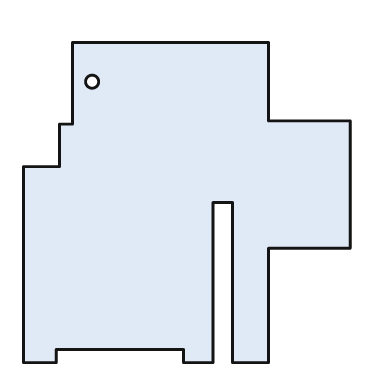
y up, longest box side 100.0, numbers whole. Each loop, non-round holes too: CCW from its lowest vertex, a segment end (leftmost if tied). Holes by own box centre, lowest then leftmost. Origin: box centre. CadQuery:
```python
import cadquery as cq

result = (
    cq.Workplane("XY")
    .moveTo(-50.0, -49.0)
    .lineTo(-40.0, -49.0)
    .lineTo(-40.0, -45.0)
    .lineTo(-1.0, -45.0)
    .lineTo(-1.0, -49.0)
    .lineTo(8.0, -49.0)
    .lineTo(8.0, 0.0)
    .lineTo(14.0, 0.0)
    .lineTo(14.0, -49.0)
    .lineTo(25.0, -49.0)
    .lineTo(25.0, -14.0)
    .lineTo(50.0, -14.0)
    .lineTo(50.0, 25.0)
    .lineTo(25.0, 25.0)
    .lineTo(25.0, 49.0)
    .lineTo(-35.0, 49.0)
    .lineTo(-35.0, 24.0)
    .lineTo(-39.0, 24.0)
    .lineTo(-39.0, 11.0)
    .lineTo(-50.0, 11.0)
    .close()
    .moveTo(-29.0, 37.0)
    .circle(2.0)
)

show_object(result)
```